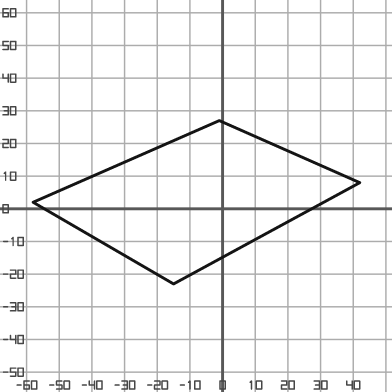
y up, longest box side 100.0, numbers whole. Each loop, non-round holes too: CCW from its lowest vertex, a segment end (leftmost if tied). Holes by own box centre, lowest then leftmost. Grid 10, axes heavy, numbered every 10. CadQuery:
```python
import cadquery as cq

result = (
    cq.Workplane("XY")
    .moveTo(-15.0, -23.0)
    .lineTo(42.0, 8.0)
    .lineTo(-1.0, 27.0)
    .lineTo(-58.0, 2.0)
    .close()
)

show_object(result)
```